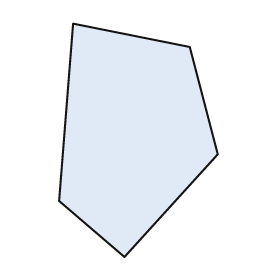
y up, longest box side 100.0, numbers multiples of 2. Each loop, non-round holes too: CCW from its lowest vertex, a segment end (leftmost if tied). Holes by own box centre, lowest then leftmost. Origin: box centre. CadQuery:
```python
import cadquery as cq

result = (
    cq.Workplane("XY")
    .moveTo(-6.0, -50.0)
    .lineTo(34.0, -6.0)
    .lineTo(22.0, 40.0)
    .lineTo(-28.0, 50.0)
    .lineTo(-34.0, -26.0)
    .close()
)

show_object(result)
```